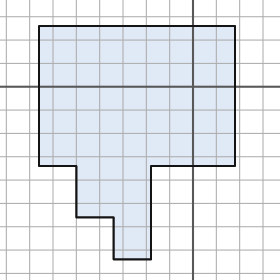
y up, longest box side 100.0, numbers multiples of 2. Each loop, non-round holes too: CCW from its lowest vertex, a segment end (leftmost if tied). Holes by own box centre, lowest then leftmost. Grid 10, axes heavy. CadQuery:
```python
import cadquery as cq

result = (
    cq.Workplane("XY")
    .moveTo(-34.0, -74.0)
    .lineTo(-18.0, -74.0)
    .lineTo(-18.0, -34.0)
    .lineTo(18.0, -34.0)
    .lineTo(18.0, 26.0)
    .lineTo(-66.0, 26.0)
    .lineTo(-66.0, -34.0)
    .lineTo(-50.0, -34.0)
    .lineTo(-50.0, -56.0)
    .lineTo(-34.0, -56.0)
    .close()
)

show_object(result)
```